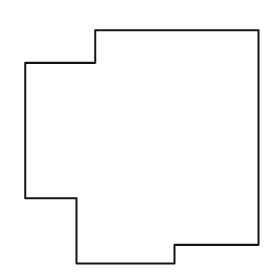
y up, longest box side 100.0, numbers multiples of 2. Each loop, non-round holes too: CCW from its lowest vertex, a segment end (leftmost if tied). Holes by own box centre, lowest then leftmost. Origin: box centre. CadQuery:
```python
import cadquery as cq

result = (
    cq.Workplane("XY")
    .moveTo(-28.0, -50.0)
    .lineTo(14.0, -50.0)
    .lineTo(14.0, -42.0)
    .lineTo(50.0, -42.0)
    .lineTo(50.0, 50.0)
    .lineTo(-20.0, 50.0)
    .lineTo(-20.0, 36.0)
    .lineTo(-50.0, 36.0)
    .lineTo(-50.0, -22.0)
    .lineTo(-28.0, -22.0)
    .close()
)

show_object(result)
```